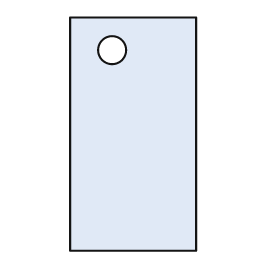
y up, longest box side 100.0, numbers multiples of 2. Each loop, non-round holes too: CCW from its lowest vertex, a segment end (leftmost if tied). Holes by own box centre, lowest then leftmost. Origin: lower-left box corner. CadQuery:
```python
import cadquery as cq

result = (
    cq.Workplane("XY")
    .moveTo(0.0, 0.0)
    .lineTo(54.0, 0.0)
    .lineTo(54.0, 100.0)
    .lineTo(0.0, 100.0)
    .close()
    .moveTo(18.0, 86.0)
    .circle(6.0)
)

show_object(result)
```